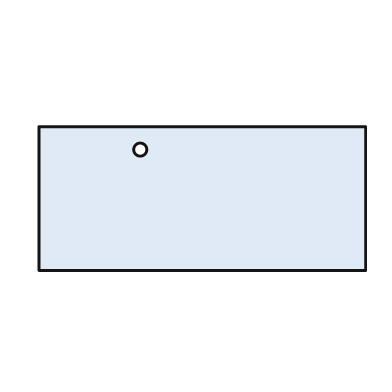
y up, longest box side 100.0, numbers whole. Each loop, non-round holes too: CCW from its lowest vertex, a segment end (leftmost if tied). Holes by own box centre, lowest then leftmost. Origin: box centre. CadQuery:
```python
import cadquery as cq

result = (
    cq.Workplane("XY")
    .moveTo(-50.0, -22.0)
    .lineTo(50.0, -22.0)
    .lineTo(50.0, 22.0)
    .lineTo(-50.0, 22.0)
    .close()
    .moveTo(-19.0, 15.0)
    .circle(2.0)
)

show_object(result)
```